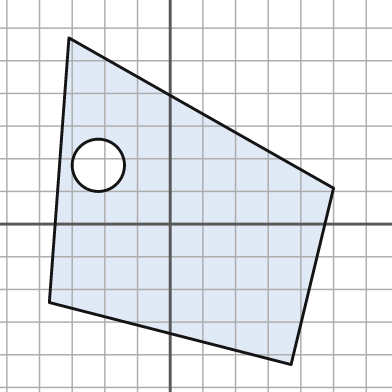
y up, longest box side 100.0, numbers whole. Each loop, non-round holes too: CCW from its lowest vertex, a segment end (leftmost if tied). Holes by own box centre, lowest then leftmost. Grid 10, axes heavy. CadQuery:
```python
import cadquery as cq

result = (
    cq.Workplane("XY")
    .moveTo(37.0, -43.0)
    .lineTo(50.0, 11.0)
    .lineTo(-31.0, 57.0)
    .lineTo(-37.0, -24.0)
    .close()
    .moveTo(-22.0, 18.0)
    .circle(8.0)
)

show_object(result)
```